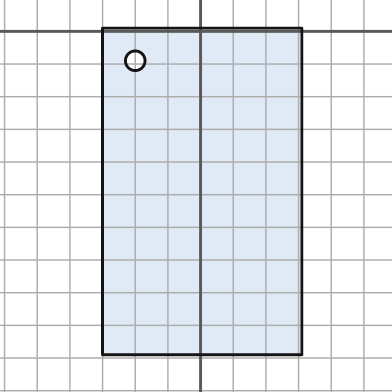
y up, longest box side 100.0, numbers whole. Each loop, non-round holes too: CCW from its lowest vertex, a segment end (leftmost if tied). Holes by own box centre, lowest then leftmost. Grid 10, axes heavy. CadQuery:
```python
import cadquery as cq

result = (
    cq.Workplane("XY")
    .moveTo(-30.0, -99.0)
    .lineTo(31.0, -99.0)
    .lineTo(31.0, 1.0)
    .lineTo(-30.0, 1.0)
    .close()
    .moveTo(-20.0, -9.0)
    .circle(3.0)
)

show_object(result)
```